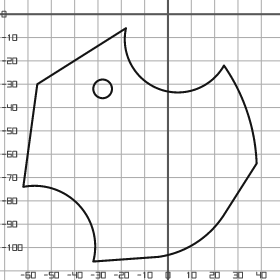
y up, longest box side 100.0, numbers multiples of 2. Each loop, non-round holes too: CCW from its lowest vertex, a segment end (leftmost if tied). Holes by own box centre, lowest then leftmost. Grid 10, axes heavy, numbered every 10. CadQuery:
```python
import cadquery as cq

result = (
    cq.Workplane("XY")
    .moveTo(-32.0, -106.0)
    .lineTo(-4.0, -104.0)
    .threePointArc((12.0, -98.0), (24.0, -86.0))
    .lineTo(38.0, -64.0)
    .threePointArc((34.0, -42.0), (24.0, -22.0))
    .threePointArc((-4.0, -32.0), (-18.0, -6.0))
    .lineTo(-56.0, -30.0)
    .lineTo(-62.0, -74.0)
    .threePointArc((-38.0, -82.0), (-32.0, -106.0))
    .close()
    .moveTo(-28.0, -32.0)
    .circle(4.0)
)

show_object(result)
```